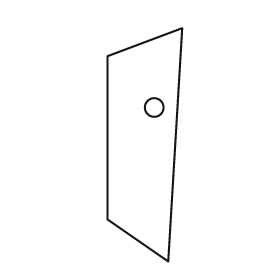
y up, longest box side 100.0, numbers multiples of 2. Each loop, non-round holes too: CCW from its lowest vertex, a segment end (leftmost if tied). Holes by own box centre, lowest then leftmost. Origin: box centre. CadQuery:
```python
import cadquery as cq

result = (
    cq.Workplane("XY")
    .moveTo(10.0, -50.0)
    .lineTo(16.0, 50.0)
    .lineTo(-16.0, 38.0)
    .lineTo(-16.0, -32.0)
    .close()
    .moveTo(4.0, 16.0)
    .circle(4.0)
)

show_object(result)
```